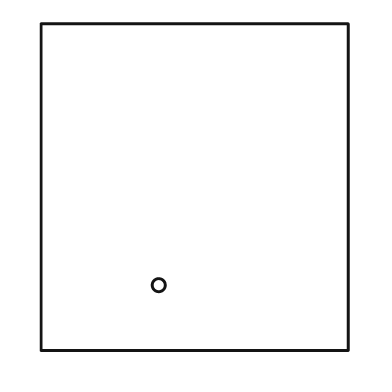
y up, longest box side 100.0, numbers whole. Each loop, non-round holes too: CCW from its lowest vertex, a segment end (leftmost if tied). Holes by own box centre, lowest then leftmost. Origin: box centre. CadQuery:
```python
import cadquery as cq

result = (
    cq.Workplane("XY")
    .moveTo(-47.0, -50.0)
    .lineTo(47.0, -50.0)
    .lineTo(47.0, 50.0)
    .lineTo(-47.0, 50.0)
    .close()
    .moveTo(-11.0, -30.0)
    .circle(2.0)
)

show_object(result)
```